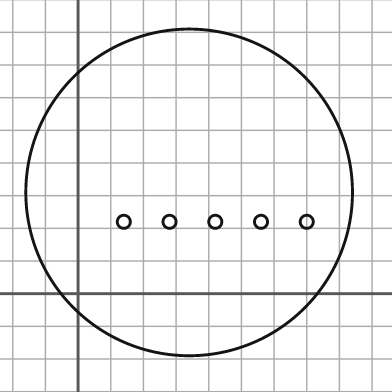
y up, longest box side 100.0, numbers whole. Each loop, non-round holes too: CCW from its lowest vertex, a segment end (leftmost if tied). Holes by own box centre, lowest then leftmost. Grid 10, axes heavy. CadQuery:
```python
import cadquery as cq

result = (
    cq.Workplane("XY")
    .moveTo(34.0, 31.0)
    .circle(50.0)
    .moveTo(14.0, 22.0)
    .circle(2.0)
    .moveTo(28.0, 22.0)
    .circle(2.0)
    .moveTo(42.0, 22.0)
    .circle(2.0)
    .moveTo(56.0, 22.0)
    .circle(2.0)
    .moveTo(70.0, 22.0)
    .circle(2.0)
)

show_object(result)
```